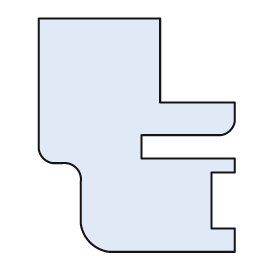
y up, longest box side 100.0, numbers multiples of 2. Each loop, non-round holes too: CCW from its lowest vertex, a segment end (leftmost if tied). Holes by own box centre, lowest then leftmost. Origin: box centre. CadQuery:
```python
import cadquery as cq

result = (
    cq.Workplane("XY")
    .moveTo(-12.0, -50.0)
    .lineTo(42.0, -50.0)
    .lineTo(42.0, -40.0)
    .lineTo(32.0, -40.0)
    .lineTo(32.0, -16.0)
    .lineTo(42.0, -16.0)
    .lineTo(42.0, -10.0)
    .lineTo(2.0, -10.0)
    .lineTo(2.0, 0.0)
    .lineTo(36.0, 0.0)
    .threePointArc((40.0, 2.0), (42.0, 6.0))
    .lineTo(42.0, 14.0)
    .lineTo(10.0, 14.0)
    .lineTo(10.0, 50.0)
    .lineTo(-42.0, 50.0)
    .lineTo(-42.0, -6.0)
    .threePointArc((-40.0, -10.0), (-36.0, -12.0))
    .lineTo(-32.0, -12.0)
    .threePointArc((-26.0, -14.0), (-24.0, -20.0))
    .lineTo(-24.0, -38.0)
    .threePointArc((-20.0, -46.0), (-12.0, -50.0))
    .close()
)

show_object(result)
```